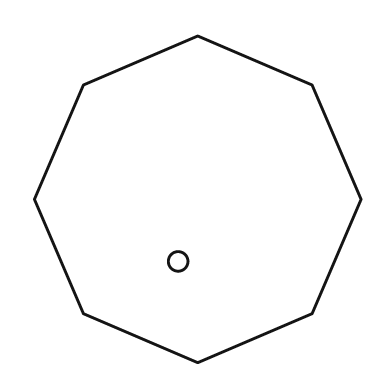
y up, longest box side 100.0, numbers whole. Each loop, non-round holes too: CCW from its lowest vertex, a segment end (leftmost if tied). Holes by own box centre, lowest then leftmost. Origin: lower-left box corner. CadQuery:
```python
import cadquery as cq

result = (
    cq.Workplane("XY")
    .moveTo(50.0, 0.0)
    .lineTo(85.0, 15.0)
    .lineTo(100.0, 50.0)
    .lineTo(85.0, 85.0)
    .lineTo(50.0, 100.0)
    .lineTo(15.0, 85.0)
    .lineTo(0.0, 50.0)
    .lineTo(15.0, 15.0)
    .close()
    .moveTo(44.0, 31.0)
    .circle(3.0)
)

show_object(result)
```